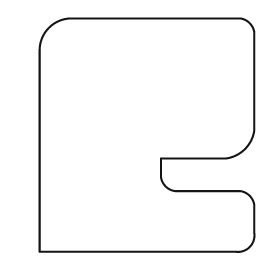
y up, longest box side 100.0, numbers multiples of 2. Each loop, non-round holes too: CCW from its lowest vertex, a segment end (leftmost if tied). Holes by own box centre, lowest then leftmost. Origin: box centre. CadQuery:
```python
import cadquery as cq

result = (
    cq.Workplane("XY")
    .moveTo(-46.0, -50.0)
    .lineTo(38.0, -50.0)
    .threePointArc((44.0, -48.0), (46.0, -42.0))
    .lineTo(46.0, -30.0)
    .threePointArc((44.0, -26.0), (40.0, -24.0))
    .lineTo(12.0, -24.0)
    .threePointArc((8.0, -22.0), (6.0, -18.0))
    .lineTo(6.0, -10.0)
    .lineTo(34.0, -10.0)
    .threePointArc((42.0, -6.0), (46.0, 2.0))
    .lineTo(46.0, 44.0)
    .threePointArc((44.0, 48.0), (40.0, 50.0))
    .lineTo(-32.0, 50.0)
    .threePointArc((-42.0, 46.0), (-46.0, 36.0))
    .close()
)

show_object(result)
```